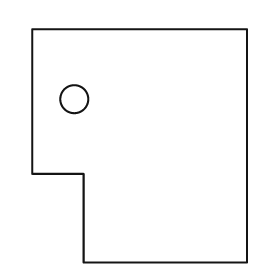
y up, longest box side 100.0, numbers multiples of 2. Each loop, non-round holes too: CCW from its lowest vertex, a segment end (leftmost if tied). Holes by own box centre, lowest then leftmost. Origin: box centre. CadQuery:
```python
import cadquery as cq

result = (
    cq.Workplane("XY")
    .moveTo(-24.0, -50.0)
    .lineTo(46.0, -50.0)
    .lineTo(46.0, 50.0)
    .lineTo(-46.0, 50.0)
    .lineTo(-46.0, -12.0)
    .lineTo(-24.0, -12.0)
    .close()
    .moveTo(-28.0, 20.0)
    .circle(6.0)
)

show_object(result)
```